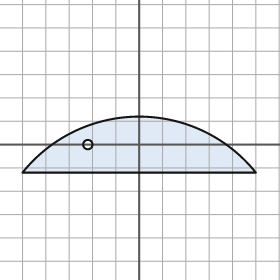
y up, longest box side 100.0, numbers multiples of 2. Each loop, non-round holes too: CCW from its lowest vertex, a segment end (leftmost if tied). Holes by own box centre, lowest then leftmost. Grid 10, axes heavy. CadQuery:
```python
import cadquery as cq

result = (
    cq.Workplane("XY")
    .moveTo(-50.0, -12.0)
    .lineTo(50.0, -12.0)
    .threePointArc((0.0, 12.0), (-50.0, -12.0))
    .close()
    .moveTo(-22.0, 0.0)
    .circle(2.0)
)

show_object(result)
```